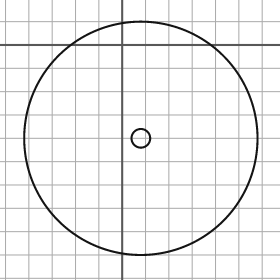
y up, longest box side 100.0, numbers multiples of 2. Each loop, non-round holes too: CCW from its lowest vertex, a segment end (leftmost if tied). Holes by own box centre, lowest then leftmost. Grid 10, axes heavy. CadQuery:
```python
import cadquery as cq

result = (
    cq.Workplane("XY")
    .moveTo(8.0, -40.0)
    .circle(50.0)
    .moveTo(8.0, -40.0)
    .circle(4.0)
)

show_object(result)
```